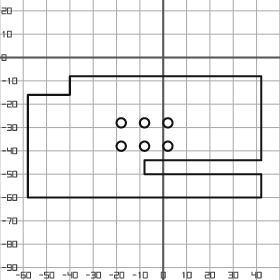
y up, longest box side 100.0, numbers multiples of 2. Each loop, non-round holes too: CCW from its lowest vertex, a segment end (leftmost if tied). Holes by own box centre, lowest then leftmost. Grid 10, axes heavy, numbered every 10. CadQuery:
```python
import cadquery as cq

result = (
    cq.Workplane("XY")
    .moveTo(-58.0, -60.0)
    .lineTo(42.0, -60.0)
    .lineTo(42.0, -50.0)
    .lineTo(-8.0, -50.0)
    .lineTo(-8.0, -44.0)
    .lineTo(42.0, -44.0)
    .lineTo(42.0, -8.0)
    .lineTo(-40.0, -8.0)
    .lineTo(-40.0, -16.0)
    .lineTo(-58.0, -16.0)
    .close()
    .moveTo(-18.0, -38.0)
    .circle(2.0)
    .moveTo(-8.0, -38.0)
    .circle(2.0)
    .moveTo(2.0, -38.0)
    .circle(2.0)
    .moveTo(-18.0, -28.0)
    .circle(2.0)
    .moveTo(-8.0, -28.0)
    .circle(2.0)
    .moveTo(2.0, -28.0)
    .circle(2.0)
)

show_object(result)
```